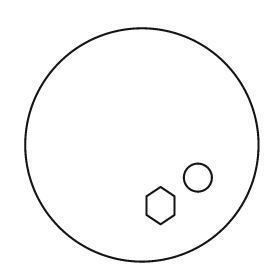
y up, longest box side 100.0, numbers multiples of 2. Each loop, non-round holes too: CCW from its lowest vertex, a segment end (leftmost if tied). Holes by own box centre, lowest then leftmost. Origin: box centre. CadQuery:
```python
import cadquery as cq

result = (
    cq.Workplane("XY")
    .moveTo(0.0, 0.0)
    .circle(50.0)
    .moveTo(8.0, -34.0)
    .lineTo(14.0, -30.0)
    .lineTo(14.0, -22.0)
    .lineTo(8.0, -18.0)
    .lineTo(2.0, -22.0)
    .lineTo(2.0, -30.0)
    .close()
    .moveTo(24.0, -14.0)
    .circle(6.0)
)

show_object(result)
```